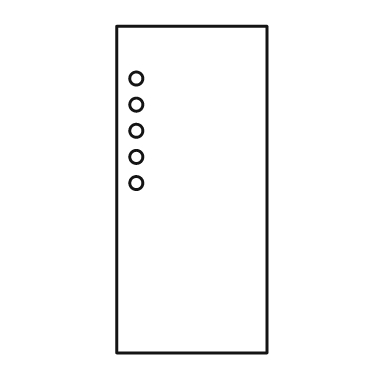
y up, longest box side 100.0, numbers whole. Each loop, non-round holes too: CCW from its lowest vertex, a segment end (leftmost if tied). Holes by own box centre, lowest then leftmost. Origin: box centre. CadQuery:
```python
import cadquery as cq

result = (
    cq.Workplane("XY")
    .moveTo(-23.0, -50.0)
    .lineTo(23.0, -50.0)
    .lineTo(23.0, 50.0)
    .lineTo(-23.0, 50.0)
    .close()
    .moveTo(-17.0, 2.0)
    .circle(2.0)
    .moveTo(-17.0, 10.0)
    .circle(2.0)
    .moveTo(-17.0, 18.0)
    .circle(2.0)
    .moveTo(-17.0, 26.0)
    .circle(2.0)
    .moveTo(-17.0, 34.0)
    .circle(2.0)
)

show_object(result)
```